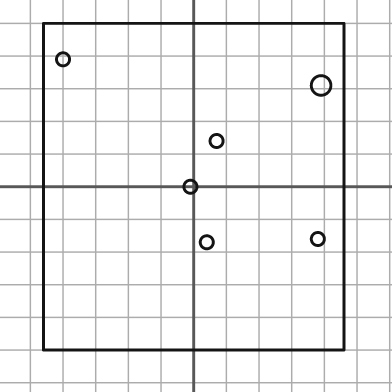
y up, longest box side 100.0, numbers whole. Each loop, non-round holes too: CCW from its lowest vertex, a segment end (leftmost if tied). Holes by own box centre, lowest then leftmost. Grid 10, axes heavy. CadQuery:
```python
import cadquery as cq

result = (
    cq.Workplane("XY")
    .moveTo(-46.0, -50.0)
    .lineTo(46.0, -50.0)
    .lineTo(46.0, 50.0)
    .lineTo(-46.0, 50.0)
    .close()
    .moveTo(4.0, -17.0)
    .circle(2.0)
    .moveTo(38.0, -16.0)
    .circle(2.0)
    .moveTo(-1.0, 0.0)
    .circle(2.0)
    .moveTo(7.0, 14.0)
    .circle(2.0)
    .moveTo(39.0, 31.0)
    .circle(3.0)
    .moveTo(-40.0, 39.0)
    .circle(2.0)
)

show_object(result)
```